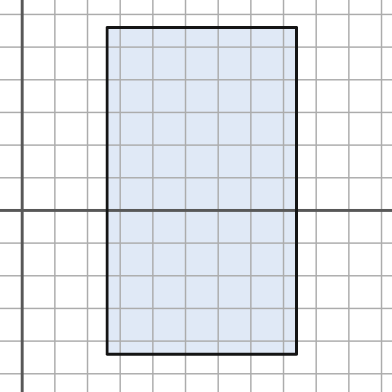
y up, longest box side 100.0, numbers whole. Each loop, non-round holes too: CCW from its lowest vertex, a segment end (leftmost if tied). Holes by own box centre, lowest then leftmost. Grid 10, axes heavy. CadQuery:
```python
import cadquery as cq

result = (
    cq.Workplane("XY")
    .moveTo(26.0, -44.0)
    .lineTo(84.0, -44.0)
    .lineTo(84.0, 56.0)
    .lineTo(26.0, 56.0)
    .close()
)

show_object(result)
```